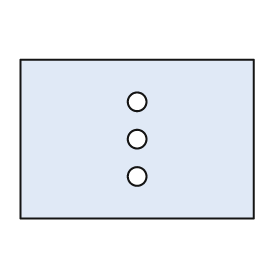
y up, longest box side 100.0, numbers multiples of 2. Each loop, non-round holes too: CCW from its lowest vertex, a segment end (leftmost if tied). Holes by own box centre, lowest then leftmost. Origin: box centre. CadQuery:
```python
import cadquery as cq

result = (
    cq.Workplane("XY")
    .moveTo(-50.0, -34.0)
    .lineTo(50.0, -34.0)
    .lineTo(50.0, 34.0)
    .lineTo(-50.0, 34.0)
    .close()
    .moveTo(0.0, -16.0)
    .circle(4.0)
    .moveTo(0.0, 0.0)
    .circle(4.0)
    .moveTo(0.0, 16.0)
    .circle(4.0)
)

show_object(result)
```